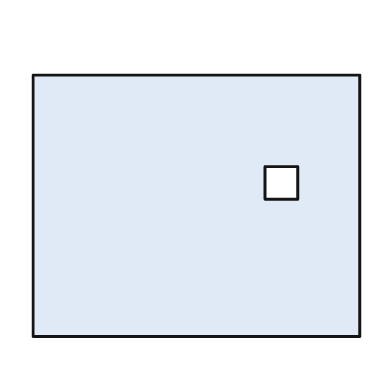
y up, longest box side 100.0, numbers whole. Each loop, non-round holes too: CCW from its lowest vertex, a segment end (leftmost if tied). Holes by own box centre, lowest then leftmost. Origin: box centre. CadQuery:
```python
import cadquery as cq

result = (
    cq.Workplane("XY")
    .moveTo(-50.0, -40.0)
    .lineTo(50.0, -40.0)
    .lineTo(50.0, 40.0)
    .lineTo(-50.0, 40.0)
    .close()
    .moveTo(21.0, 2.0)
    .lineTo(31.0, 2.0)
    .lineTo(31.0, 12.0)
    .lineTo(21.0, 12.0)
    .close()
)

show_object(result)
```